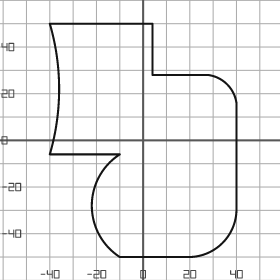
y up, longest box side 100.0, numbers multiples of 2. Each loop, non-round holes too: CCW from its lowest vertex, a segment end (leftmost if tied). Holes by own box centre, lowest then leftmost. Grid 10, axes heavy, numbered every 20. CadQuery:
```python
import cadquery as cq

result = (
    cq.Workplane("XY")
    .moveTo(-10.0, -50.0)
    .lineTo(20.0, -50.0)
    .threePointArc((34.0, -44.0), (40.0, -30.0))
    .lineTo(40.0, 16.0)
    .threePointArc((36.0, 24.0), (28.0, 28.0))
    .lineTo(4.0, 28.0)
    .lineTo(4.0, 50.0)
    .lineTo(-40.0, 50.0)
    .threePointArc((-36.0, 22.0), (-40.0, -6.0))
    .lineTo(-10.0, -6.0)
    .threePointArc((-22.0, -28.0), (-10.0, -50.0))
    .close()
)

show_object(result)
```